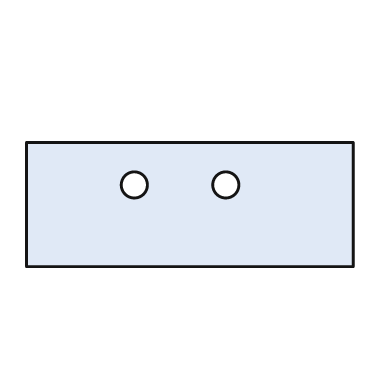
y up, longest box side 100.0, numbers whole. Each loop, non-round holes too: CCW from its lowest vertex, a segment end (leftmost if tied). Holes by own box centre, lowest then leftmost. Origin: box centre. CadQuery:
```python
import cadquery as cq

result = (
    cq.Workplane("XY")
    .moveTo(-50.0, -19.0)
    .lineTo(50.0, -19.0)
    .lineTo(50.0, 19.0)
    .lineTo(-50.0, 19.0)
    .close()
    .moveTo(-17.0, 6.0)
    .circle(4.0)
    .moveTo(11.0, 6.0)
    .circle(4.0)
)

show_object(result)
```